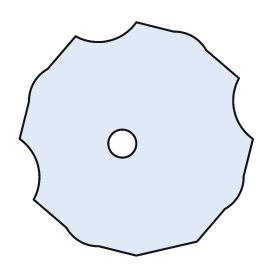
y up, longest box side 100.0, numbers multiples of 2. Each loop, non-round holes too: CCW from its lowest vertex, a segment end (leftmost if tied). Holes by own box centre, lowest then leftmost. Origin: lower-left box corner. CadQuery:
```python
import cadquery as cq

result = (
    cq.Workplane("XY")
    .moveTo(50.0, 0.0)
    .lineTo(76.0, 6.0)
    .lineTo(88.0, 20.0)
    .threePointArc((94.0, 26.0), (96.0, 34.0))
    .lineTo(100.0, 50.0)
    .threePointArc((92.0, 62.0), (94.0, 76.0))
    .lineTo(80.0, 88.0)
    .threePointArc((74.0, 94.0), (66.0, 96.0))
    .lineTo(50.0, 100.0)
    .threePointArc((38.0, 92.0), (24.0, 94.0))
    .lineTo(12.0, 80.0)
    .threePointArc((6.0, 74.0), (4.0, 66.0))
    .lineTo(0.0, 50.0)
    .threePointArc((8.0, 38.0), (6.0, 24.0))
    .lineTo(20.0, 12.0)
    .threePointArc((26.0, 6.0), (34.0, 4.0))
    .close()
    .moveTo(44.0, 48.0)
    .circle(6.0)
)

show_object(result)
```